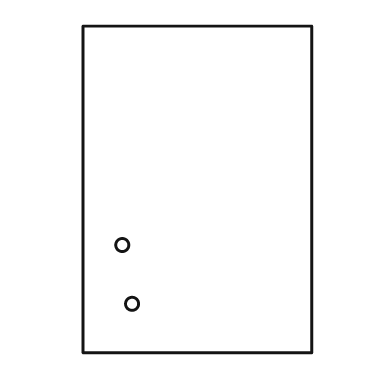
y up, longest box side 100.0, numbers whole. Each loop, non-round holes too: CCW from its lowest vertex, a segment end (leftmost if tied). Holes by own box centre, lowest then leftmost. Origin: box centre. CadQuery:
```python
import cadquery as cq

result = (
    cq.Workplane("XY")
    .moveTo(-35.0, -50.0)
    .lineTo(35.0, -50.0)
    .lineTo(35.0, 50.0)
    .lineTo(-35.0, 50.0)
    .close()
    .moveTo(-20.0, -35.0)
    .circle(2.0)
    .moveTo(-23.0, -17.0)
    .circle(2.0)
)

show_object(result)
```